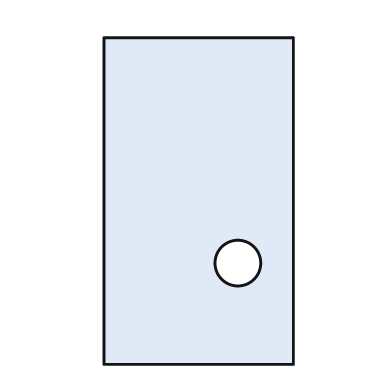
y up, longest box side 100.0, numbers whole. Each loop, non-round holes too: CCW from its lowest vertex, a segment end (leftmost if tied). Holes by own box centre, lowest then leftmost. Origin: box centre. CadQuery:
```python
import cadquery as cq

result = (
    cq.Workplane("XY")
    .moveTo(-29.0, -50.0)
    .lineTo(29.0, -50.0)
    .lineTo(29.0, 50.0)
    .lineTo(-29.0, 50.0)
    .close()
    .moveTo(12.0, -19.0)
    .circle(7.0)
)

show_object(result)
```